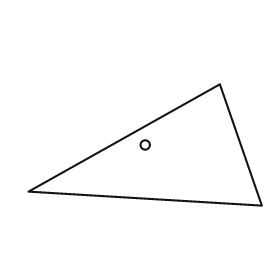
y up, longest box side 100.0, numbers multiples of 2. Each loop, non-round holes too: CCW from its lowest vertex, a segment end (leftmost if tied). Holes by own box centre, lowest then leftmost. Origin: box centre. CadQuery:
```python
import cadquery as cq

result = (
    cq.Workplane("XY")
    .moveTo(50.0, -26.0)
    .lineTo(32.0, 26.0)
    .lineTo(-50.0, -20.0)
    .close()
    .moveTo(0.0, 0.0)
    .circle(2.0)
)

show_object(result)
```